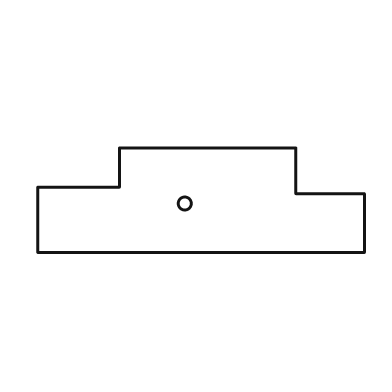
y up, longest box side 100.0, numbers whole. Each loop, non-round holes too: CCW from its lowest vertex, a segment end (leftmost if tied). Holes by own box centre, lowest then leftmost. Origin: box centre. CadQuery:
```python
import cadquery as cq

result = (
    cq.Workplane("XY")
    .moveTo(-50.0, -16.0)
    .lineTo(50.0, -16.0)
    .lineTo(50.0, 2.0)
    .lineTo(29.0, 2.0)
    .lineTo(29.0, 16.0)
    .lineTo(-25.0, 16.0)
    .lineTo(-25.0, 4.0)
    .lineTo(-50.0, 4.0)
    .close()
    .moveTo(-5.0, -1.0)
    .circle(2.0)
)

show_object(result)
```